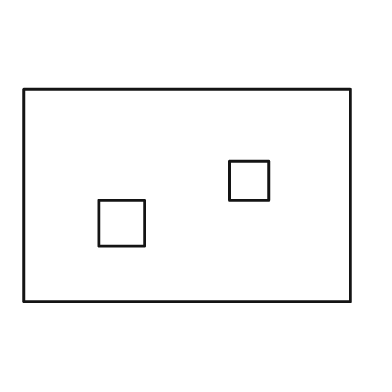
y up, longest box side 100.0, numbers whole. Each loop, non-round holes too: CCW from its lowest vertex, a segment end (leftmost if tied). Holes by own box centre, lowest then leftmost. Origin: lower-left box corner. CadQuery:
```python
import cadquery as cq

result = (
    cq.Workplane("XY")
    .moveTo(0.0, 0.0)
    .lineTo(100.0, 0.0)
    .lineTo(100.0, 65.0)
    .lineTo(0.0, 65.0)
    .close()
    .moveTo(23.0, 17.0)
    .lineTo(37.0, 17.0)
    .lineTo(37.0, 31.0)
    .lineTo(23.0, 31.0)
    .close()
    .moveTo(63.0, 31.0)
    .lineTo(75.0, 31.0)
    .lineTo(75.0, 43.0)
    .lineTo(63.0, 43.0)
    .close()
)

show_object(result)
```